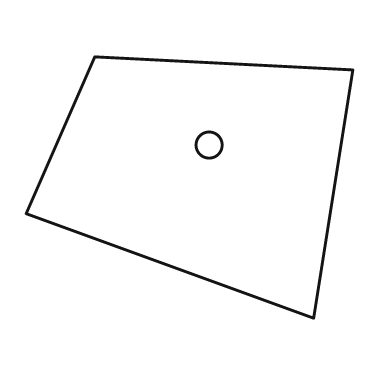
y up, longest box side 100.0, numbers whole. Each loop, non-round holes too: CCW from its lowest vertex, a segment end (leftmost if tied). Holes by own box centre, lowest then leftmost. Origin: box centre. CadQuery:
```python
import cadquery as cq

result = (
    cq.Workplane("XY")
    .moveTo(38.0, -40.0)
    .lineTo(50.0, 36.0)
    .lineTo(-29.0, 40.0)
    .lineTo(-50.0, -8.0)
    .close()
    .moveTo(6.0, 13.0)
    .circle(4.0)
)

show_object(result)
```